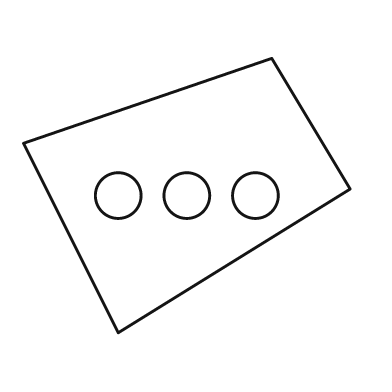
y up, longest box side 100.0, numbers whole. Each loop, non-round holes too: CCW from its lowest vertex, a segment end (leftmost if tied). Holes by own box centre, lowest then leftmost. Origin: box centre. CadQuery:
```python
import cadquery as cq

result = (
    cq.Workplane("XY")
    .moveTo(-21.0, -42.0)
    .lineTo(50.0, 2.0)
    .lineTo(26.0, 42.0)
    .lineTo(-50.0, 16.0)
    .close()
    .moveTo(-21.0, 0.0)
    .circle(7.0)
    .moveTo(0.0, 0.0)
    .circle(7.0)
    .moveTo(21.0, 0.0)
    .circle(7.0)
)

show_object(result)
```